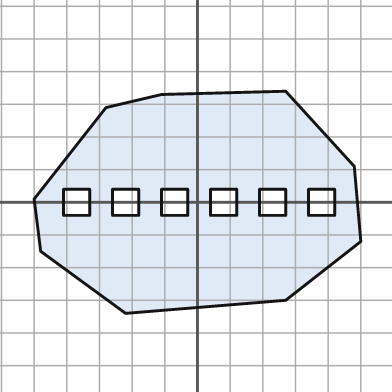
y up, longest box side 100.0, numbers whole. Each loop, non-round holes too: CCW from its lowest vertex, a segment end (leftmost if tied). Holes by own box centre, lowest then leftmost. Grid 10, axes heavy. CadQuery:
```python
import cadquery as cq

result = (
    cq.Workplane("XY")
    .moveTo(-22.0, -34.0)
    .lineTo(27.0, -30.0)
    .lineTo(50.0, -12.0)
    .lineTo(48.0, 11.0)
    .lineTo(27.0, 34.0)
    .lineTo(-11.0, 33.0)
    .lineTo(-28.0, 29.0)
    .lineTo(-50.0, 1.0)
    .lineTo(-48.0, -15.0)
    .close()
    .moveTo(-41.0, -4.0)
    .lineTo(-33.0, -4.0)
    .lineTo(-33.0, 4.0)
    .lineTo(-41.0, 4.0)
    .close()
    .moveTo(-26.0, -4.0)
    .lineTo(-18.0, -4.0)
    .lineTo(-18.0, 4.0)
    .lineTo(-26.0, 4.0)
    .close()
    .moveTo(-11.0, -4.0)
    .lineTo(-3.0, -4.0)
    .lineTo(-3.0, 4.0)
    .lineTo(-11.0, 4.0)
    .close()
    .moveTo(4.0, -4.0)
    .lineTo(12.0, -4.0)
    .lineTo(12.0, 4.0)
    .lineTo(4.0, 4.0)
    .close()
    .moveTo(19.0, -4.0)
    .lineTo(27.0, -4.0)
    .lineTo(27.0, 4.0)
    .lineTo(19.0, 4.0)
    .close()
    .moveTo(34.0, -4.0)
    .lineTo(42.0, -4.0)
    .lineTo(42.0, 4.0)
    .lineTo(34.0, 4.0)
    .close()
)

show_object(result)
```